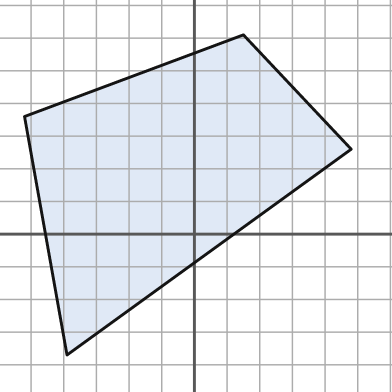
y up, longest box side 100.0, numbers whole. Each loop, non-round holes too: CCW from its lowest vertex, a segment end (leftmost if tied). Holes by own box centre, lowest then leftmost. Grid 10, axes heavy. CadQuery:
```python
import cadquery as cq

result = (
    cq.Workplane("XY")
    .moveTo(-39.0, -37.0)
    .lineTo(48.0, 26.0)
    .lineTo(15.0, 61.0)
    .lineTo(-52.0, 36.0)
    .close()
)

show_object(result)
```